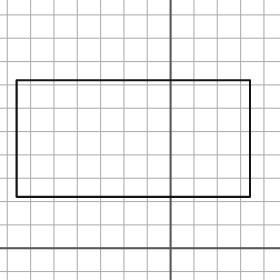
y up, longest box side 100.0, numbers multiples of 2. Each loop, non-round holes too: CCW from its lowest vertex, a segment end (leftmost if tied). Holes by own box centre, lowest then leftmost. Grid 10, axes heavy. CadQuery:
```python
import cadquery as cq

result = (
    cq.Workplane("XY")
    .moveTo(-66.0, 22.0)
    .lineTo(34.0, 22.0)
    .lineTo(34.0, 72.0)
    .lineTo(-66.0, 72.0)
    .close()
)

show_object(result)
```